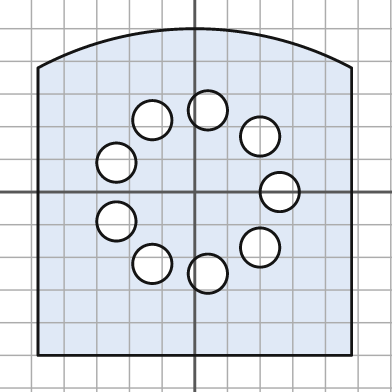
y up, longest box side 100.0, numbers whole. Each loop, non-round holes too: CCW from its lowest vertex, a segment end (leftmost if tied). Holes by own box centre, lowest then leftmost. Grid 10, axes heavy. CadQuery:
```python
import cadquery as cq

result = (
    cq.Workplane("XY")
    .moveTo(-48.0, -50.0)
    .lineTo(48.0, -50.0)
    .lineTo(48.0, 38.0)
    .threePointArc((0.0, 50.0), (-48.0, 38.0))
    .close()
    .moveTo(4.0, -25.0)
    .circle(6.0)
    .moveTo(-13.0, -22.0)
    .circle(6.0)
    .moveTo(20.0, -17.0)
    .circle(6.0)
    .moveTo(-24.0, -9.0)
    .circle(6.0)
    .moveTo(26.0, 0.0)
    .circle(6.0)
    .moveTo(-24.0, 9.0)
    .circle(6.0)
    .moveTo(20.0, 17.0)
    .circle(6.0)
    .moveTo(-13.0, 22.0)
    .circle(6.0)
    .moveTo(4.0, 25.0)
    .circle(6.0)
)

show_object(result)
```